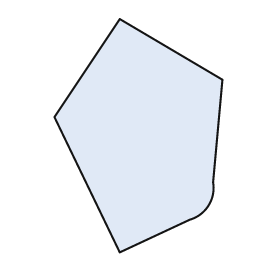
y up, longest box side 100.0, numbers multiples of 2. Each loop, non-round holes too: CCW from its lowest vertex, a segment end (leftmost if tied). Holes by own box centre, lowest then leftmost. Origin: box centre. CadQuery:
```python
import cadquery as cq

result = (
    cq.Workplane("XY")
    .moveTo(-8.0, -50.0)
    .lineTo(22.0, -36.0)
    .threePointArc((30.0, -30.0), (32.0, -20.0))
    .lineTo(36.0, 24.0)
    .lineTo(-8.0, 50.0)
    .lineTo(-36.0, 8.0)
    .close()
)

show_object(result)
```